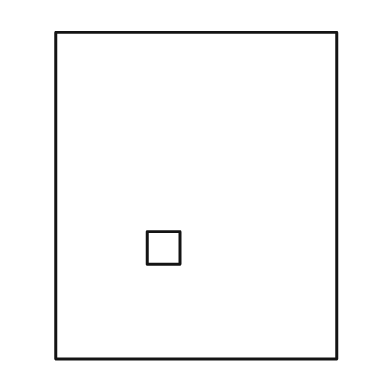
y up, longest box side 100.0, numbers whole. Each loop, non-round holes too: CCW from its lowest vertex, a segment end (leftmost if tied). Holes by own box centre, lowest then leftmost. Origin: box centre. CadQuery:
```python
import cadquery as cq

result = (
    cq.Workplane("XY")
    .moveTo(-43.0, -50.0)
    .lineTo(43.0, -50.0)
    .lineTo(43.0, 50.0)
    .lineTo(-43.0, 50.0)
    .close()
    .moveTo(-15.0, -21.0)
    .lineTo(-5.0, -21.0)
    .lineTo(-5.0, -11.0)
    .lineTo(-15.0, -11.0)
    .close()
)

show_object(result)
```